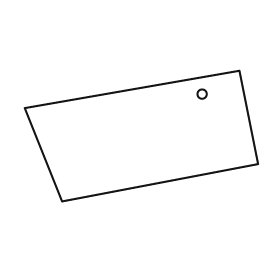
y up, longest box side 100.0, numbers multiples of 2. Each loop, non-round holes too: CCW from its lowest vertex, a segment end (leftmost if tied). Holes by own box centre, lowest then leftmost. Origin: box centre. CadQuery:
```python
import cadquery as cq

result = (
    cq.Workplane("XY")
    .moveTo(-34.0, -28.0)
    .lineTo(50.0, -12.0)
    .lineTo(42.0, 28.0)
    .lineTo(-50.0, 12.0)
    .close()
    .moveTo(26.0, 18.0)
    .circle(2.0)
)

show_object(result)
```